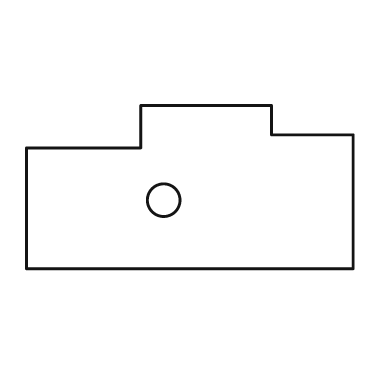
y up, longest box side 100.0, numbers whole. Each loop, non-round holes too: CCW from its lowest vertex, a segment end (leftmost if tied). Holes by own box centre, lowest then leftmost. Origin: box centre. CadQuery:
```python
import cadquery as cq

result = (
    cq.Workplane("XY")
    .moveTo(-50.0, -25.0)
    .lineTo(50.0, -25.0)
    .lineTo(50.0, 16.0)
    .lineTo(25.0, 16.0)
    .lineTo(25.0, 25.0)
    .lineTo(-15.0, 25.0)
    .lineTo(-15.0, 12.0)
    .lineTo(-50.0, 12.0)
    .close()
    .moveTo(-8.0, -4.0)
    .circle(5.0)
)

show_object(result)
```